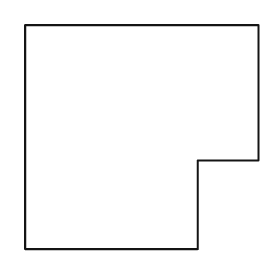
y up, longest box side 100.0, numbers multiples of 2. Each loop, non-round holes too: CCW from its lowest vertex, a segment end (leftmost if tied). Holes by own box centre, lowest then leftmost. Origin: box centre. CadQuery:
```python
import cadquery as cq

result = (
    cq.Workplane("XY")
    .moveTo(-50.0, -48.0)
    .lineTo(24.0, -48.0)
    .lineTo(24.0, -10.0)
    .lineTo(50.0, -10.0)
    .lineTo(50.0, 48.0)
    .lineTo(-50.0, 48.0)
    .close()
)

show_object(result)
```